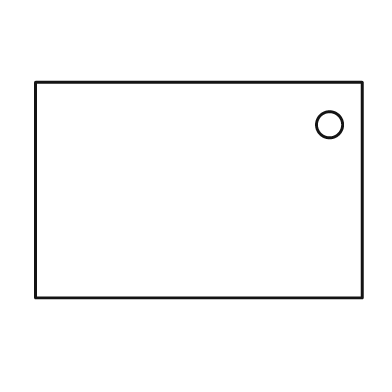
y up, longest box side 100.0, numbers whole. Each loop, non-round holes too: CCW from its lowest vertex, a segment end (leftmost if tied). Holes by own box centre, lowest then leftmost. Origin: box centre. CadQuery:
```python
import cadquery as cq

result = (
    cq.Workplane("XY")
    .moveTo(-50.0, -33.0)
    .lineTo(50.0, -33.0)
    .lineTo(50.0, 33.0)
    .lineTo(-50.0, 33.0)
    .close()
    .moveTo(40.0, 20.0)
    .circle(4.0)
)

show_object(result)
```